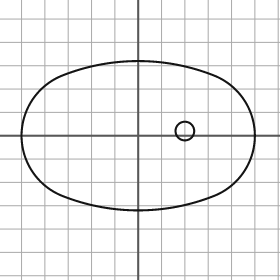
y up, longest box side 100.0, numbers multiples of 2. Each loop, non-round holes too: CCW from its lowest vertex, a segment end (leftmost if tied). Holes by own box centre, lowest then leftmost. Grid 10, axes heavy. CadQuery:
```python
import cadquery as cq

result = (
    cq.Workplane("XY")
    .moveTo(-32.0, -26.0)
    .threePointArc((0.0, -32.0), (32.0, -26.0))
    .threePointArc((50.0, 0.0), (32.0, 26.0))
    .threePointArc((0.0, 32.0), (-32.0, 26.0))
    .threePointArc((-50.0, 0.0), (-32.0, -26.0))
    .close()
    .moveTo(20.0, 2.0)
    .circle(4.0)
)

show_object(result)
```